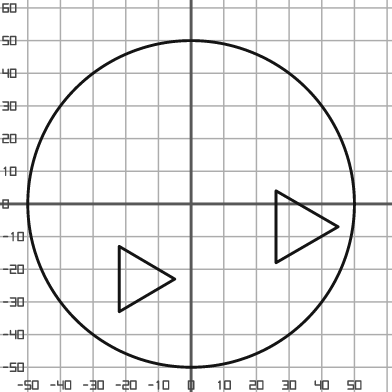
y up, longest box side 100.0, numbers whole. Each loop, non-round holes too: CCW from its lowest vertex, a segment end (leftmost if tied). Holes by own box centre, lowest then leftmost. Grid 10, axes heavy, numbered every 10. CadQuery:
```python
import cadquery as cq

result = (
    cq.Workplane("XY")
    .moveTo(0.0, 0.0)
    .circle(50.0)
    .moveTo(-22.0, -33.0)
    .lineTo(-5.0, -23.0)
    .lineTo(-22.0, -13.0)
    .close()
    .moveTo(26.0, -18.0)
    .lineTo(45.0, -7.0)
    .lineTo(26.0, 4.0)
    .close()
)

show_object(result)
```